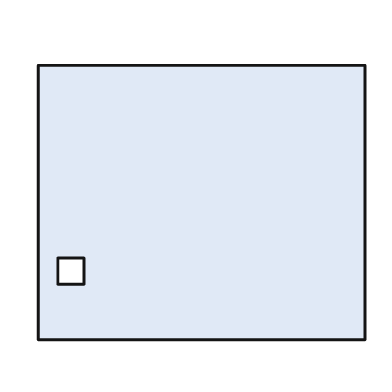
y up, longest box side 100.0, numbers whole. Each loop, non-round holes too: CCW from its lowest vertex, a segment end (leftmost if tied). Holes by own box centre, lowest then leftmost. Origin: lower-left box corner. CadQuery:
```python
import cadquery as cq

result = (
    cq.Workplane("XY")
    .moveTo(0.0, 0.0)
    .lineTo(100.0, 0.0)
    .lineTo(100.0, 84.0)
    .lineTo(0.0, 84.0)
    .close()
    .moveTo(6.0, 17.0)
    .lineTo(14.0, 17.0)
    .lineTo(14.0, 25.0)
    .lineTo(6.0, 25.0)
    .close()
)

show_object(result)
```